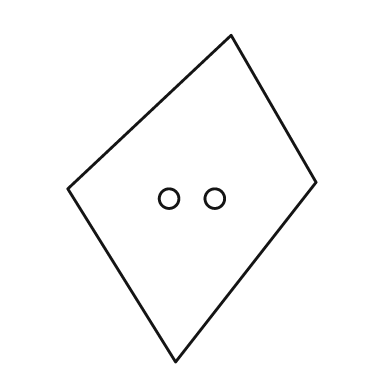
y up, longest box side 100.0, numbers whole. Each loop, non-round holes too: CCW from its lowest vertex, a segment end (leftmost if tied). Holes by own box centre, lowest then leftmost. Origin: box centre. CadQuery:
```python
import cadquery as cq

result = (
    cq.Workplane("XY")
    .moveTo(-5.0, -50.0)
    .lineTo(38.0, 5.0)
    .lineTo(12.0, 50.0)
    .lineTo(-38.0, 3.0)
    .close()
    .moveTo(-7.0, 0.0)
    .circle(3.0)
    .moveTo(7.0, 0.0)
    .circle(3.0)
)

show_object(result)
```